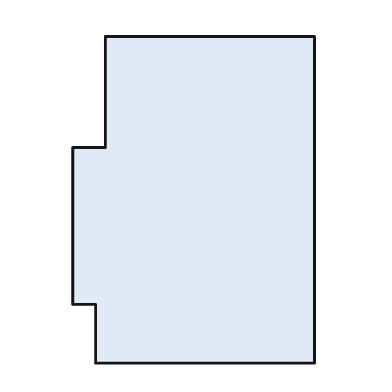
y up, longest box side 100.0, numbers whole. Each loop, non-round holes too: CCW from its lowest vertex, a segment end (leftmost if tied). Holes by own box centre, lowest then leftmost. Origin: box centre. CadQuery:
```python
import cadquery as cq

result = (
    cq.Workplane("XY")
    .moveTo(-30.0, -50.0)
    .lineTo(37.0, -50.0)
    .lineTo(37.0, 50.0)
    .lineTo(-27.0, 50.0)
    .lineTo(-27.0, 16.0)
    .lineTo(-37.0, 16.0)
    .lineTo(-37.0, -32.0)
    .lineTo(-30.0, -32.0)
    .close()
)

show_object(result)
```